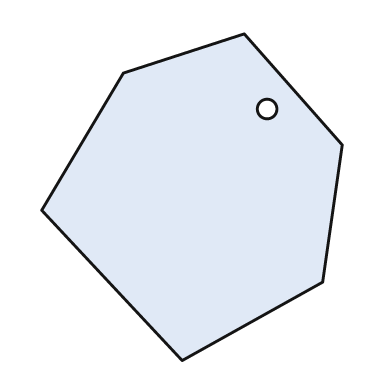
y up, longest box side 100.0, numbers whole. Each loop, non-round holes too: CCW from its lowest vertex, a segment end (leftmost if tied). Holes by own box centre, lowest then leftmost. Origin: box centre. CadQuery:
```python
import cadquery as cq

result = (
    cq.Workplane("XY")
    .moveTo(-3.0, -50.0)
    .lineTo(40.0, -26.0)
    .lineTo(46.0, 16.0)
    .lineTo(16.0, 50.0)
    .lineTo(-21.0, 38.0)
    .lineTo(-46.0, -4.0)
    .close()
    .moveTo(23.0, 27.0)
    .circle(3.0)
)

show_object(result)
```